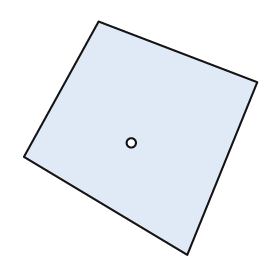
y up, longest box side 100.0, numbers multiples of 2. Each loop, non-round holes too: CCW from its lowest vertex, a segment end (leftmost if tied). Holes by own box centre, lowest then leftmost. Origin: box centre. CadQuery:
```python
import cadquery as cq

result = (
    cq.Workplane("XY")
    .moveTo(20.0, -50.0)
    .lineTo(50.0, 24.0)
    .lineTo(-18.0, 50.0)
    .lineTo(-50.0, -8.0)
    .close()
    .moveTo(-4.0, -2.0)
    .circle(2.0)
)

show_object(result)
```